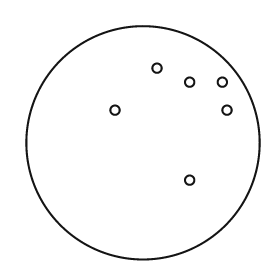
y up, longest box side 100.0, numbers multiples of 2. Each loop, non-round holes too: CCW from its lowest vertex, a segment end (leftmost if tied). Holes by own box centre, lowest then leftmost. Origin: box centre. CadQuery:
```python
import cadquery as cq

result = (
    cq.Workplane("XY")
    .moveTo(0.0, 0.0)
    .circle(50.0)
    .moveTo(20.0, -16.0)
    .circle(2.0)
    .moveTo(-12.0, 14.0)
    .circle(2.0)
    .moveTo(36.0, 14.0)
    .circle(2.0)
    .moveTo(20.0, 26.0)
    .circle(2.0)
    .moveTo(34.0, 26.0)
    .circle(2.0)
    .moveTo(6.0, 32.0)
    .circle(2.0)
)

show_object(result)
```